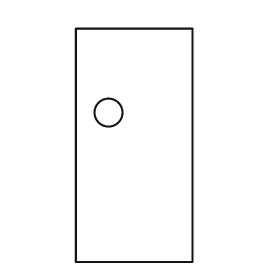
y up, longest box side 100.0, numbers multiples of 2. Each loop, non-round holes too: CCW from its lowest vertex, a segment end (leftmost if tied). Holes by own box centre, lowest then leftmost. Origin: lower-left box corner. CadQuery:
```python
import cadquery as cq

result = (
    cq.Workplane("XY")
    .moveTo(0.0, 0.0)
    .lineTo(50.0, 0.0)
    .lineTo(50.0, 100.0)
    .lineTo(0.0, 100.0)
    .close()
    .moveTo(14.0, 64.0)
    .circle(6.0)
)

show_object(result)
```